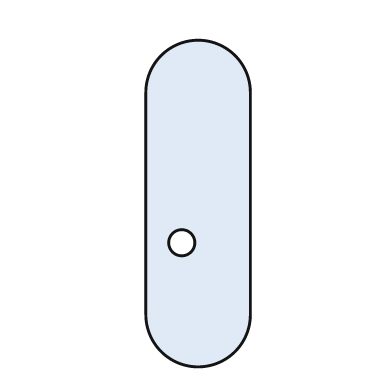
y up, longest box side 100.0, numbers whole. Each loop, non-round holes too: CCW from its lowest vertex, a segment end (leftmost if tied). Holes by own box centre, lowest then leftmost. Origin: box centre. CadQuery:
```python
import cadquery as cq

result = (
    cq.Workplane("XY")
    .moveTo(-16.0, -34.0)
    .threePointArc((0.0, -50.0), (16.0, -34.0))
    .lineTo(16.0, 34.0)
    .threePointArc((0.0, 50.0), (-16.0, 34.0))
    .close()
    .moveTo(-5.0, -12.0)
    .circle(4.0)
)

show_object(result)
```